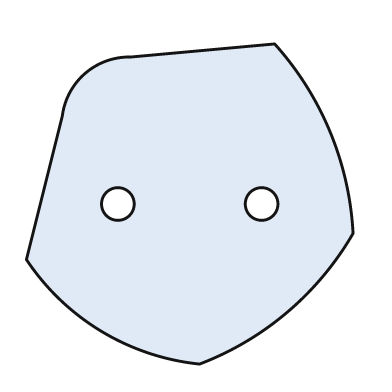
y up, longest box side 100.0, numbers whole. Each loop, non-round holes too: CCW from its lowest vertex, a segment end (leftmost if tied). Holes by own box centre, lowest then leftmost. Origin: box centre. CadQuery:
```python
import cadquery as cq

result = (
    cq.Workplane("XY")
    .moveTo(3.0, -49.0)
    .threePointArc((30.0, -33.0), (50.0, -9.0))
    .threePointArc((43.0, 22.0), (26.0, 49.0))
    .lineTo(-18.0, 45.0)
    .threePointArc((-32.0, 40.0), (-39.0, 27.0))
    .lineTo(-50.0, -17.0)
    .threePointArc((-27.0, -39.0), (3.0, -49.0))
    .close()
    .moveTo(-22.0, 0.0)
    .circle(5.0)
    .moveTo(22.0, 0.0)
    .circle(5.0)
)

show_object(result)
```